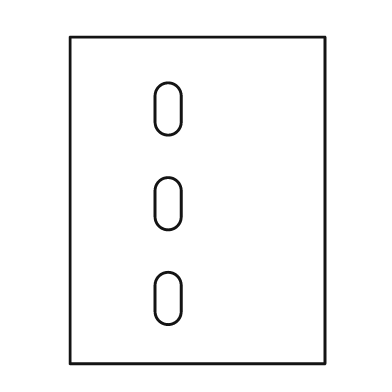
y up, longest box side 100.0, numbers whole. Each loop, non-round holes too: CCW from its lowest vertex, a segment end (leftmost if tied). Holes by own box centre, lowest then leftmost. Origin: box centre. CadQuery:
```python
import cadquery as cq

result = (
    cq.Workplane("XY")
    .moveTo(-39.0, -50.0)
    .lineTo(39.0, -50.0)
    .lineTo(39.0, 50.0)
    .lineTo(-39.0, 50.0)
    .close()
    .moveTo(-13.0, -34.0)
    .threePointArc((-9.0, -38.0), (-5.0, -34.0))
    .lineTo(-5.0, -26.0)
    .threePointArc((-9.0, -22.0), (-13.0, -26.0))
    .close()
    .moveTo(-13.0, -5.0)
    .threePointArc((-9.0, -9.0), (-5.0, -5.0))
    .lineTo(-5.0, 3.0)
    .threePointArc((-9.0, 7.0), (-13.0, 3.0))
    .close()
    .moveTo(-13.0, 24.0)
    .threePointArc((-9.0, 20.0), (-5.0, 24.0))
    .lineTo(-5.0, 32.0)
    .threePointArc((-9.0, 36.0), (-13.0, 32.0))
    .close()
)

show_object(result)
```